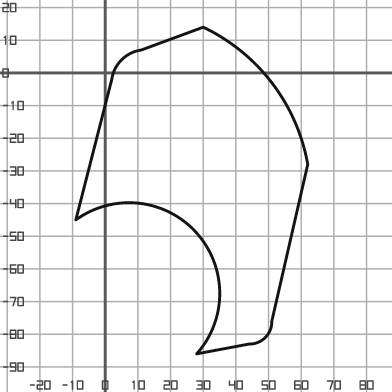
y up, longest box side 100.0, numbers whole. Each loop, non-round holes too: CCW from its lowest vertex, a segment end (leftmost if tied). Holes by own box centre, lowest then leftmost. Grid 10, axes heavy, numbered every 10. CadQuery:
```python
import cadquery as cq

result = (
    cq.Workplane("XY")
    .moveTo(28.0, -86.0)
    .lineTo(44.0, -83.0)
    .threePointArc((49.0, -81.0), (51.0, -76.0))
    .lineTo(62.0, -28.0)
    .threePointArc((51.0, -3.0), (30.0, 14.0))
    .lineTo(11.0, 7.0)
    .threePointArc((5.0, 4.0), (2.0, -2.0))
    .lineTo(-9.0, -45.0)
    .threePointArc((28.0, -49.0), (28.0, -86.0))
    .close()
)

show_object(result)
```